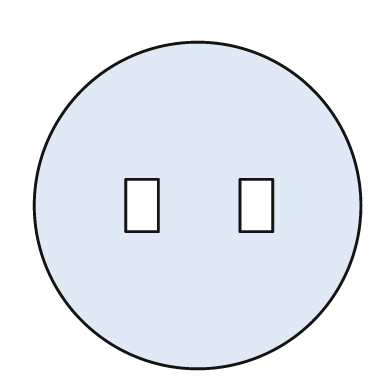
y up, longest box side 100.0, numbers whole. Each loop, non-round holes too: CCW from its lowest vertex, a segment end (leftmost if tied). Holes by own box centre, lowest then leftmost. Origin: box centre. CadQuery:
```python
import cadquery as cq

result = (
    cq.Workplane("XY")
    .moveTo(0.0, 0.0)
    .circle(50.0)
    .moveTo(-22.0, -8.0)
    .lineTo(-12.0, -8.0)
    .lineTo(-12.0, 8.0)
    .lineTo(-22.0, 8.0)
    .close()
    .moveTo(13.0, -8.0)
    .lineTo(23.0, -8.0)
    .lineTo(23.0, 8.0)
    .lineTo(13.0, 8.0)
    .close()
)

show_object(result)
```